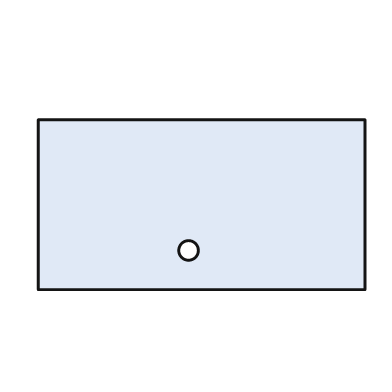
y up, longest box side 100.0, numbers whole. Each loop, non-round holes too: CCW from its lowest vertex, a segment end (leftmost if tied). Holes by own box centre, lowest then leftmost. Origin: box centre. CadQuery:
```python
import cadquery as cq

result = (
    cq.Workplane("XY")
    .moveTo(-50.0, -26.0)
    .lineTo(50.0, -26.0)
    .lineTo(50.0, 26.0)
    .lineTo(-50.0, 26.0)
    .close()
    .moveTo(-4.0, -14.0)
    .circle(3.0)
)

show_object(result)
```